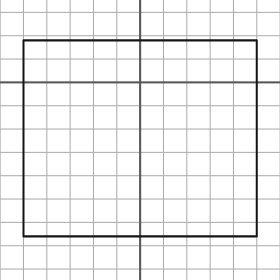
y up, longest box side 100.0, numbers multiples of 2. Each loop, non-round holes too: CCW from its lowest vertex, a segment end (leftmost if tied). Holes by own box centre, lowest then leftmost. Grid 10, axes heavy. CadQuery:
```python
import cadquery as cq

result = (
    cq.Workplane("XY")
    .moveTo(-50.0, -66.0)
    .lineTo(50.0, -66.0)
    .lineTo(50.0, 18.0)
    .lineTo(-50.0, 18.0)
    .close()
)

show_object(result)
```